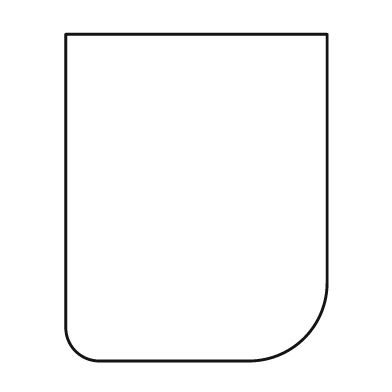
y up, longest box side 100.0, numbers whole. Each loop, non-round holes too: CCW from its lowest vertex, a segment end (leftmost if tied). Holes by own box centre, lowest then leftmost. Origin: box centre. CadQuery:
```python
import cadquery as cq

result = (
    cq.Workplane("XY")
    .moveTo(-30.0, -50.0)
    .lineTo(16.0, -50.0)
    .threePointArc((33.0, -43.0), (40.0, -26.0))
    .lineTo(40.0, 50.0)
    .lineTo(-40.0, 50.0)
    .lineTo(-40.0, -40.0)
    .threePointArc((-37.0, -47.0), (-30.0, -50.0))
    .close()
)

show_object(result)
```